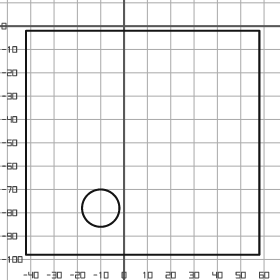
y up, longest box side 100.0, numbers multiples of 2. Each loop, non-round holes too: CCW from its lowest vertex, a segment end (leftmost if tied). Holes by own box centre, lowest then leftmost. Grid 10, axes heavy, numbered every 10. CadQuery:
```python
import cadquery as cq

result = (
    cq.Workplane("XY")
    .moveTo(-42.0, -98.0)
    .lineTo(58.0, -98.0)
    .lineTo(58.0, -2.0)
    .lineTo(-42.0, -2.0)
    .close()
    .moveTo(-10.0, -78.0)
    .circle(8.0)
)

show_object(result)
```